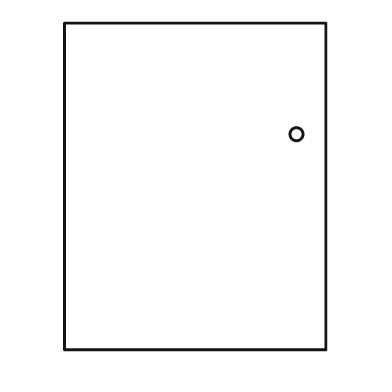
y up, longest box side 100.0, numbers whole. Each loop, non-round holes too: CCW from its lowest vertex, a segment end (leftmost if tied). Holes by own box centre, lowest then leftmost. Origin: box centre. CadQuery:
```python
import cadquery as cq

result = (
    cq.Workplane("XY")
    .moveTo(-40.0, -50.0)
    .lineTo(40.0, -50.0)
    .lineTo(40.0, 50.0)
    .lineTo(-40.0, 50.0)
    .close()
    .moveTo(31.0, 16.0)
    .circle(2.0)
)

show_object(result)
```